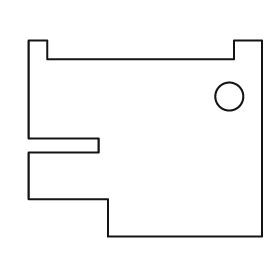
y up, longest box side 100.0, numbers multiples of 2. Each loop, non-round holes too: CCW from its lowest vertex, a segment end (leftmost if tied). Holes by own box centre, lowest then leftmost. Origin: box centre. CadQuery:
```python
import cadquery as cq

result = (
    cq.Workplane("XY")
    .moveTo(-16.0, -42.0)
    .lineTo(50.0, -42.0)
    .lineTo(50.0, 42.0)
    .lineTo(38.0, 42.0)
    .lineTo(38.0, 34.0)
    .lineTo(-42.0, 34.0)
    .lineTo(-42.0, 42.0)
    .lineTo(-50.0, 42.0)
    .lineTo(-50.0, 0.0)
    .lineTo(-20.0, 0.0)
    .lineTo(-20.0, -6.0)
    .lineTo(-50.0, -6.0)
    .lineTo(-50.0, -26.0)
    .lineTo(-16.0, -26.0)
    .close()
    .moveTo(36.0, 18.0)
    .circle(6.0)
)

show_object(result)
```